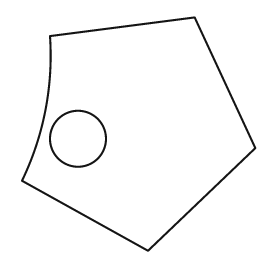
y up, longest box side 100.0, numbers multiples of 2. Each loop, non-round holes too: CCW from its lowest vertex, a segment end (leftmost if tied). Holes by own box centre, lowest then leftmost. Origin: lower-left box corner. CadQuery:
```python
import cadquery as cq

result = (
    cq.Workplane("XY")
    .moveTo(54.0, 0.0)
    .lineTo(100.0, 44.0)
    .lineTo(74.0, 100.0)
    .lineTo(12.0, 92.0)
    .threePointArc((10.0, 60.0), (0.0, 30.0))
    .close()
    .moveTo(24.0, 48.0)
    .circle(12.0)
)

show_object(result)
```